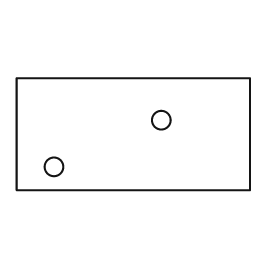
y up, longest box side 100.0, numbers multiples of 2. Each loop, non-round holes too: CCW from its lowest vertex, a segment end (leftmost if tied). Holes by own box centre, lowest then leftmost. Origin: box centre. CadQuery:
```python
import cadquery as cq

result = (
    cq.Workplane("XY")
    .moveTo(-50.0, -24.0)
    .lineTo(50.0, -24.0)
    .lineTo(50.0, 24.0)
    .lineTo(-50.0, 24.0)
    .close()
    .moveTo(-34.0, -14.0)
    .circle(4.0)
    .moveTo(12.0, 6.0)
    .circle(4.0)
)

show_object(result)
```